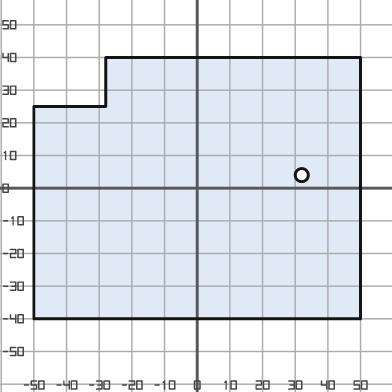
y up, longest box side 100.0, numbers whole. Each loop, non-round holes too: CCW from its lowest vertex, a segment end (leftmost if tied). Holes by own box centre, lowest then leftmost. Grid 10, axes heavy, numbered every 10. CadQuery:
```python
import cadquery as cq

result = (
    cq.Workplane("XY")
    .moveTo(-50.0, -40.0)
    .lineTo(50.0, -40.0)
    .lineTo(50.0, 40.0)
    .lineTo(-28.0, 40.0)
    .lineTo(-28.0, 25.0)
    .lineTo(-50.0, 25.0)
    .close()
    .moveTo(32.0, 4.0)
    .circle(2.0)
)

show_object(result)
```